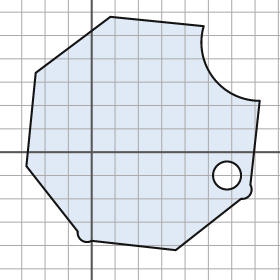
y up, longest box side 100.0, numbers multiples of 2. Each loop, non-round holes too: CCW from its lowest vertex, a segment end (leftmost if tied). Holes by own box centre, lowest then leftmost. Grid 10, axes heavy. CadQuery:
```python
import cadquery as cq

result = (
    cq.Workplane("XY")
    .moveTo(36.0, -42.0)
    .lineTo(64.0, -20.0)
    .threePointArc((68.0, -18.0), (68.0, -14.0))
    .lineTo(72.0, 22.0)
    .threePointArc((52.0, 32.0), (48.0, 54.0))
    .lineTo(8.0, 58.0)
    .lineTo(-24.0, 34.0)
    .lineTo(-28.0, -6.0)
    .lineTo(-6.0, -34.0)
    .threePointArc((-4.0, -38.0), (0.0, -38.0))
    .close()
    .moveTo(58.0, -10.0)
    .circle(6.0)
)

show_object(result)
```